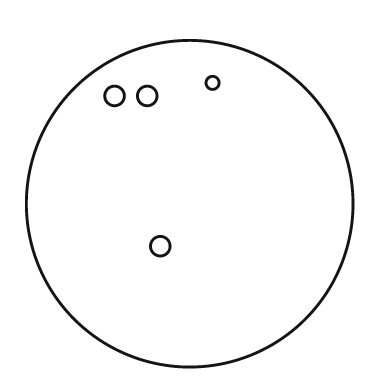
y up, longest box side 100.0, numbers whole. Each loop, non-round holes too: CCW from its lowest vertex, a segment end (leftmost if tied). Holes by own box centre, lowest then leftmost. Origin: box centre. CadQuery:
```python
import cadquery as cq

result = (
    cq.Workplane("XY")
    .moveTo(0.0, 0.0)
    .circle(50.0)
    .moveTo(-9.0, -13.0)
    .circle(3.0)
    .moveTo(-23.0, 33.0)
    .circle(3.0)
    .moveTo(-13.0, 33.0)
    .circle(3.0)
    .moveTo(7.0, 37.0)
    .circle(2.0)
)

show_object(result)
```